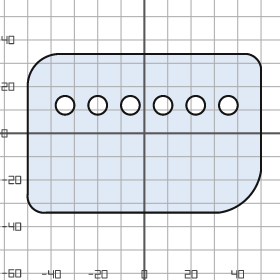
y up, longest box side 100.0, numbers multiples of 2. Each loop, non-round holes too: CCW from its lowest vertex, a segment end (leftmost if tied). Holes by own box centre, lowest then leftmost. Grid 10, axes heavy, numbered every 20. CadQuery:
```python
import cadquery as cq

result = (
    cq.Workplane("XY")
    .moveTo(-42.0, -34.0)
    .lineTo(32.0, -34.0)
    .threePointArc((44.0, -28.0), (50.0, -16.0))
    .lineTo(50.0, 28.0)
    .threePointArc((48.0, 32.0), (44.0, 34.0))
    .lineTo(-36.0, 34.0)
    .threePointArc((-46.0, 30.0), (-50.0, 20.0))
    .lineTo(-50.0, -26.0)
    .threePointArc((-48.0, -32.0), (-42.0, -34.0))
    .close()
    .moveTo(-34.0, 12.0)
    .circle(4.0)
    .moveTo(-20.0, 12.0)
    .circle(4.0)
    .moveTo(-6.0, 12.0)
    .circle(4.0)
    .moveTo(8.0, 12.0)
    .circle(4.0)
    .moveTo(22.0, 12.0)
    .circle(4.0)
    .moveTo(36.0, 12.0)
    .circle(4.0)
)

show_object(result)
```